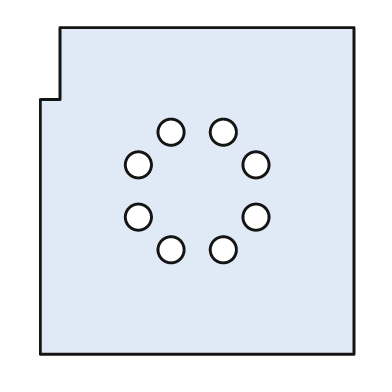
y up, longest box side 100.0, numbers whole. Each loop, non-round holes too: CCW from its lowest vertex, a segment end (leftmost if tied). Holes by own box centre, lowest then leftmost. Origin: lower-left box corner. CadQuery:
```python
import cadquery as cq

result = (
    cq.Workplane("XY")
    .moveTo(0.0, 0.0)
    .lineTo(96.0, 0.0)
    .lineTo(96.0, 100.0)
    .lineTo(6.0, 100.0)
    .lineTo(6.0, 78.0)
    .lineTo(0.0, 78.0)
    .close()
    .moveTo(40.0, 32.0)
    .circle(4.0)
    .moveTo(56.0, 32.0)
    .circle(4.0)
    .moveTo(30.0, 42.0)
    .circle(4.0)
    .moveTo(66.0, 42.0)
    .circle(4.0)
    .moveTo(30.0, 58.0)
    .circle(4.0)
    .moveTo(66.0, 58.0)
    .circle(4.0)
    .moveTo(40.0, 68.0)
    .circle(4.0)
    .moveTo(56.0, 68.0)
    .circle(4.0)
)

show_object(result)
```